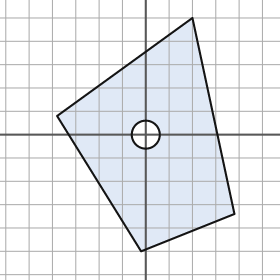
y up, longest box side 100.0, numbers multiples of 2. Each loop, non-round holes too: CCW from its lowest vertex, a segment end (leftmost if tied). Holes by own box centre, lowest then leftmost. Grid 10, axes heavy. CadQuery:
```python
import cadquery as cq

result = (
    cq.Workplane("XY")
    .moveTo(-2.0, -50.0)
    .lineTo(38.0, -34.0)
    .lineTo(20.0, 50.0)
    .lineTo(-38.0, 8.0)
    .close()
    .moveTo(0.0, 0.0)
    .circle(6.0)
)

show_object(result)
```